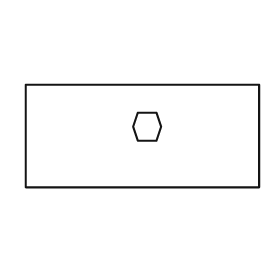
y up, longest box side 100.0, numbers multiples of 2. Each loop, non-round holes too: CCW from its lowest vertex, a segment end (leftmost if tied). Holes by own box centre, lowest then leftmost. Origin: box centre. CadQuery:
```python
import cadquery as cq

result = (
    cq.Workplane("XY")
    .moveTo(-50.0, -22.0)
    .lineTo(50.0, -22.0)
    .lineTo(50.0, 22.0)
    .lineTo(-50.0, 22.0)
    .close()
    .moveTo(-2.0, -2.0)
    .lineTo(6.0, -2.0)
    .lineTo(8.0, 4.0)
    .lineTo(6.0, 10.0)
    .lineTo(-2.0, 10.0)
    .lineTo(-4.0, 4.0)
    .close()
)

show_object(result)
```